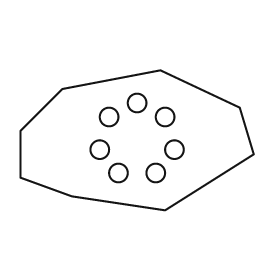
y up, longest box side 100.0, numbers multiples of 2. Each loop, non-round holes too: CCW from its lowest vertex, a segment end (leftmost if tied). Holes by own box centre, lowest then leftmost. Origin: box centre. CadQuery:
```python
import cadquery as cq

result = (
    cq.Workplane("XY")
    .moveTo(12.0, -30.0)
    .lineTo(50.0, -6.0)
    .lineTo(44.0, 14.0)
    .lineTo(10.0, 30.0)
    .lineTo(-32.0, 22.0)
    .lineTo(-50.0, 4.0)
    .lineTo(-50.0, -16.0)
    .lineTo(-28.0, -24.0)
    .close()
    .moveTo(-8.0, -14.0)
    .circle(4.0)
    .moveTo(8.0, -14.0)
    .circle(4.0)
    .moveTo(-16.0, -4.0)
    .circle(4.0)
    .moveTo(16.0, -4.0)
    .circle(4.0)
    .moveTo(-12.0, 10.0)
    .circle(4.0)
    .moveTo(12.0, 10.0)
    .circle(4.0)
    .moveTo(0.0, 16.0)
    .circle(4.0)
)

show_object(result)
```